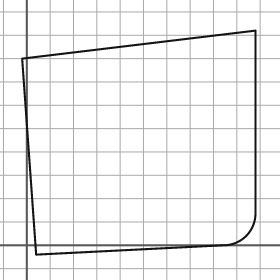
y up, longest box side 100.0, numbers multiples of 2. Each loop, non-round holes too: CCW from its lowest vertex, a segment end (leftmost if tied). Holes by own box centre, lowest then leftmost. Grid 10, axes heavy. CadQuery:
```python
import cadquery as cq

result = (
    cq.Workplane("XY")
    .moveTo(4.0, -4.0)
    .lineTo(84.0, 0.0)
    .threePointArc((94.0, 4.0), (98.0, 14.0))
    .lineTo(98.0, 92.0)
    .lineTo(-2.0, 80.0)
    .close()
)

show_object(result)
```